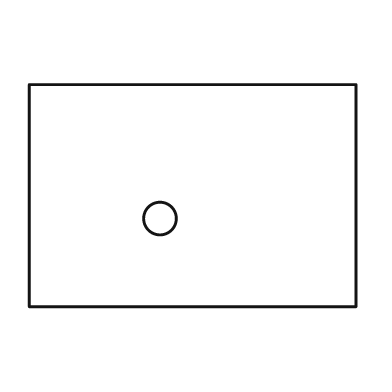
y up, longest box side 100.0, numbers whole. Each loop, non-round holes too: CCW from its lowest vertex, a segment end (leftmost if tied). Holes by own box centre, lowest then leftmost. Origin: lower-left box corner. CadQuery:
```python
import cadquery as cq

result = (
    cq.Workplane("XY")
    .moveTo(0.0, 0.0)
    .lineTo(100.0, 0.0)
    .lineTo(100.0, 68.0)
    .lineTo(0.0, 68.0)
    .close()
    .moveTo(40.0, 27.0)
    .circle(5.0)
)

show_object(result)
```